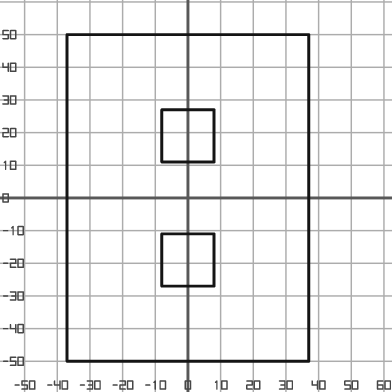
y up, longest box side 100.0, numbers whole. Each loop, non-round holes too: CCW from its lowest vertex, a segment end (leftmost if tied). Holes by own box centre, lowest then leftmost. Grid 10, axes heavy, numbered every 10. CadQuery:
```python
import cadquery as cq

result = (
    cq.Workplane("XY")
    .moveTo(-37.0, -50.0)
    .lineTo(37.0, -50.0)
    .lineTo(37.0, 50.0)
    .lineTo(-37.0, 50.0)
    .close()
    .moveTo(-8.0, -27.0)
    .lineTo(8.0, -27.0)
    .lineTo(8.0, -11.0)
    .lineTo(-8.0, -11.0)
    .close()
    .moveTo(-8.0, 11.0)
    .lineTo(8.0, 11.0)
    .lineTo(8.0, 27.0)
    .lineTo(-8.0, 27.0)
    .close()
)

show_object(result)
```